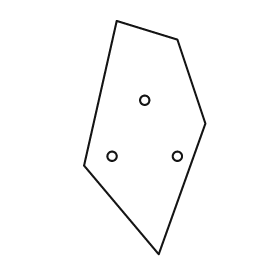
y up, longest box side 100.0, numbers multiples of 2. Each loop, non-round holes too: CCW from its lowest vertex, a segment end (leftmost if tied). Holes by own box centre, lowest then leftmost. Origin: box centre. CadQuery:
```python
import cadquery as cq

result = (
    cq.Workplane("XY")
    .moveTo(6.0, -50.0)
    .lineTo(26.0, 6.0)
    .lineTo(14.0, 42.0)
    .lineTo(-12.0, 50.0)
    .lineTo(-26.0, -12.0)
    .close()
    .moveTo(-14.0, -8.0)
    .circle(2.0)
    .moveTo(14.0, -8.0)
    .circle(2.0)
    .moveTo(0.0, 16.0)
    .circle(2.0)
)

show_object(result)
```